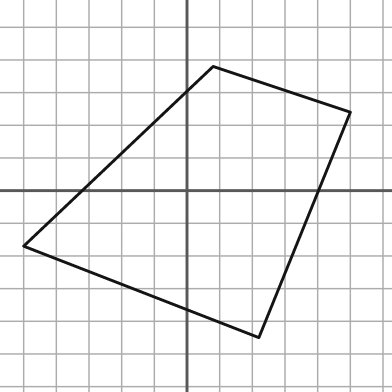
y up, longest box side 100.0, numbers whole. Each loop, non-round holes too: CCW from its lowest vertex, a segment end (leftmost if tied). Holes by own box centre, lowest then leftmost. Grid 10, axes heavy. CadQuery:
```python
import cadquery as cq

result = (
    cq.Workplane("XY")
    .moveTo(22.0, -45.0)
    .lineTo(50.0, 24.0)
    .lineTo(8.0, 38.0)
    .lineTo(-50.0, -17.0)
    .close()
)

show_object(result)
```